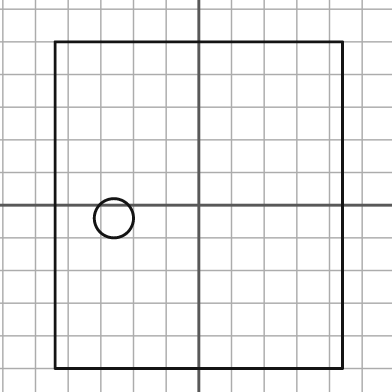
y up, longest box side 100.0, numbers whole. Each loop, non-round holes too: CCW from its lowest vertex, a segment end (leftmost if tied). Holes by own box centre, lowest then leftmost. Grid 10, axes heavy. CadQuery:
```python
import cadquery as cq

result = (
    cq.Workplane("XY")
    .moveTo(-44.0, -50.0)
    .lineTo(44.0, -50.0)
    .lineTo(44.0, 50.0)
    .lineTo(-44.0, 50.0)
    .close()
    .moveTo(-26.0, -4.0)
    .circle(6.0)
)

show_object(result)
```